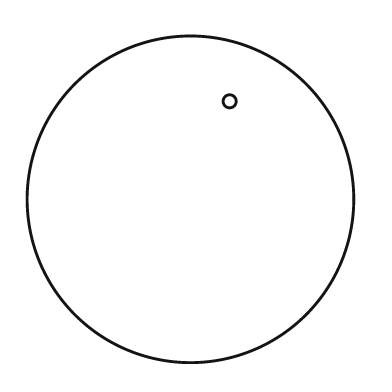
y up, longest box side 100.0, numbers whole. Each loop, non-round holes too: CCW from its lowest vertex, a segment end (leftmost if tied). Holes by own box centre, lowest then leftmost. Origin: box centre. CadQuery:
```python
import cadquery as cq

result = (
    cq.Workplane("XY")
    .moveTo(0.0, 0.0)
    .circle(50.0)
    .moveTo(12.0, 30.0)
    .circle(2.0)
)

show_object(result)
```